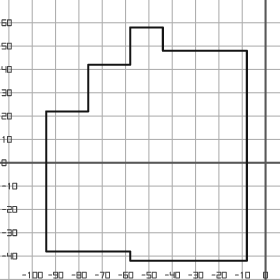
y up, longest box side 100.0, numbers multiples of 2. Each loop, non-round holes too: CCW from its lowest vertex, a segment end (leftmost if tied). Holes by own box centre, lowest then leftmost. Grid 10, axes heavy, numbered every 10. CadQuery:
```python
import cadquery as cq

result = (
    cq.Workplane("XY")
    .moveTo(-58.0, -42.0)
    .lineTo(-8.0, -42.0)
    .lineTo(-8.0, 48.0)
    .lineTo(-44.0, 48.0)
    .lineTo(-44.0, 58.0)
    .lineTo(-58.0, 58.0)
    .lineTo(-58.0, 42.0)
    .lineTo(-76.0, 42.0)
    .lineTo(-76.0, 22.0)
    .lineTo(-94.0, 22.0)
    .lineTo(-94.0, -38.0)
    .lineTo(-58.0, -38.0)
    .close()
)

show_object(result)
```